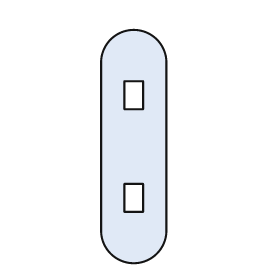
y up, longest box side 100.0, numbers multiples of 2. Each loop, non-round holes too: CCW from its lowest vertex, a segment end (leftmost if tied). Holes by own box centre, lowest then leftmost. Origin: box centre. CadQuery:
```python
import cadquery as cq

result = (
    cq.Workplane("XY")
    .moveTo(-14.0, -36.0)
    .threePointArc((0.0, -50.0), (14.0, -36.0))
    .lineTo(14.0, 36.0)
    .threePointArc((0.0, 50.0), (-14.0, 36.0))
    .close()
    .moveTo(-4.0, -28.0)
    .lineTo(4.0, -28.0)
    .lineTo(4.0, -16.0)
    .lineTo(-4.0, -16.0)
    .close()
    .moveTo(-4.0, 16.0)
    .lineTo(4.0, 16.0)
    .lineTo(4.0, 28.0)
    .lineTo(-4.0, 28.0)
    .close()
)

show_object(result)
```